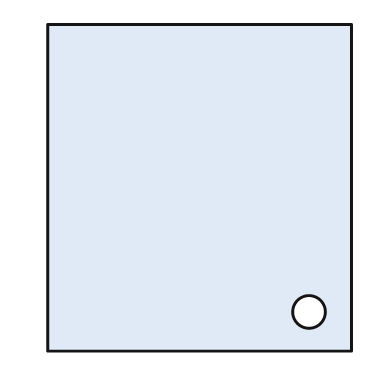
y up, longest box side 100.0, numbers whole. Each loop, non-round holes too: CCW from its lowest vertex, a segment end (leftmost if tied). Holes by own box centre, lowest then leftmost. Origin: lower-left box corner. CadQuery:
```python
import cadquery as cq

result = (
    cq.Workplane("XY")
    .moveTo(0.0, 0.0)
    .lineTo(93.0, 0.0)
    .lineTo(93.0, 100.0)
    .lineTo(0.0, 100.0)
    .close()
    .moveTo(80.0, 12.0)
    .circle(5.0)
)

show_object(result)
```